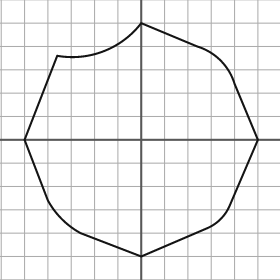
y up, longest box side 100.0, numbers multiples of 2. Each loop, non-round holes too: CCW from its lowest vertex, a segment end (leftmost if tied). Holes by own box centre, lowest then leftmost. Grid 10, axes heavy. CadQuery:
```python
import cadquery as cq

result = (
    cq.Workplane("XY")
    .moveTo(0.0, -50.0)
    .lineTo(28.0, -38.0)
    .threePointArc((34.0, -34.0), (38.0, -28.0))
    .lineTo(50.0, 0.0)
    .lineTo(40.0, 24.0)
    .threePointArc((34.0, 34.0), (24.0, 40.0))
    .lineTo(0.0, 50.0)
    .threePointArc((-16.0, 38.0), (-36.0, 36.0))
    .lineTo(-50.0, 0.0)
    .lineTo(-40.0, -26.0)
    .threePointArc((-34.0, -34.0), (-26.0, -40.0))
    .close()
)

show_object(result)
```